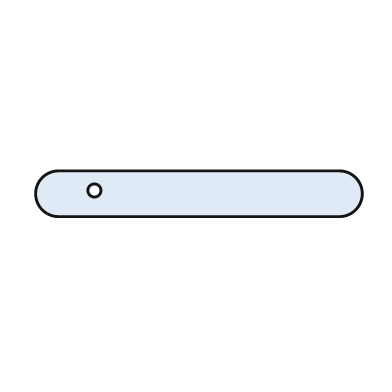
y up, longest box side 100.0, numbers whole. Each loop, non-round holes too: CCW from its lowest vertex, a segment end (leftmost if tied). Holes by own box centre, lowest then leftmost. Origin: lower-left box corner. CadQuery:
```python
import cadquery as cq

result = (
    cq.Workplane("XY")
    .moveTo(7.0, 0.0)
    .lineTo(93.0, 0.0)
    .threePointArc((100.0, 7.0), (93.0, 14.0))
    .lineTo(7.0, 14.0)
    .threePointArc((0.0, 7.0), (7.0, 0.0))
    .close()
    .moveTo(18.0, 8.0)
    .circle(2.0)
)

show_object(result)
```